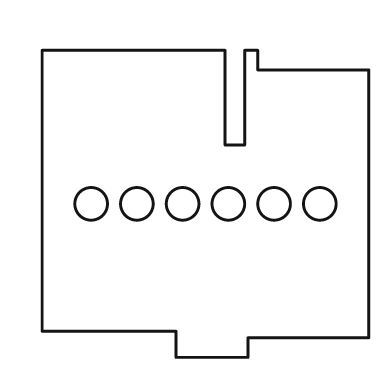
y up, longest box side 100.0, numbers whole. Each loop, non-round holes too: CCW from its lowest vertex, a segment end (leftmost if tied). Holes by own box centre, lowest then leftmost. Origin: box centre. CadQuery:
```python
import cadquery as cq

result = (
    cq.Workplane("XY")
    .moveTo(-9.0, -47.0)
    .lineTo(13.0, -47.0)
    .lineTo(13.0, -41.0)
    .lineTo(50.0, -41.0)
    .lineTo(50.0, 41.0)
    .lineTo(16.0, 41.0)
    .lineTo(16.0, 47.0)
    .lineTo(12.0, 47.0)
    .lineTo(12.0, 18.0)
    .lineTo(6.0, 18.0)
    .lineTo(6.0, 47.0)
    .lineTo(-50.0, 47.0)
    .lineTo(-50.0, -39.0)
    .lineTo(-9.0, -39.0)
    .close()
    .moveTo(-35.0, 0.0)
    .circle(5.0)
    .moveTo(-21.0, 0.0)
    .circle(5.0)
    .moveTo(-7.0, 0.0)
    .circle(5.0)
    .moveTo(7.0, 0.0)
    .circle(5.0)
    .moveTo(21.0, 0.0)
    .circle(5.0)
    .moveTo(35.0, 0.0)
    .circle(5.0)
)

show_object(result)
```